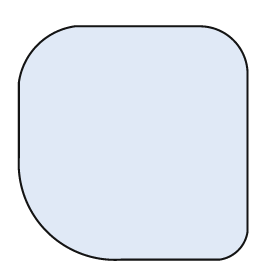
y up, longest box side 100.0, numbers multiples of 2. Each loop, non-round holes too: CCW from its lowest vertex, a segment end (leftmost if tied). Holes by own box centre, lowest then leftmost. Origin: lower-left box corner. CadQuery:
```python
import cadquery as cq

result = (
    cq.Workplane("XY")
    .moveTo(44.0, 0.0)
    .lineTo(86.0, 0.0)
    .threePointArc((94.0, 4.0), (98.0, 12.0))
    .lineTo(98.0, 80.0)
    .threePointArc((92.0, 94.0), (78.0, 100.0))
    .lineTo(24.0, 100.0)
    .threePointArc((8.0, 92.0), (0.0, 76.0))
    .lineTo(0.0, 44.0)
    .threePointArc((12.0, 12.0), (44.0, 0.0))
    .close()
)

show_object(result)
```